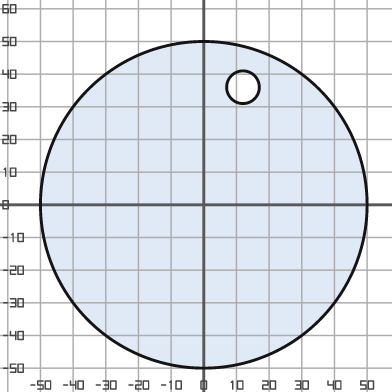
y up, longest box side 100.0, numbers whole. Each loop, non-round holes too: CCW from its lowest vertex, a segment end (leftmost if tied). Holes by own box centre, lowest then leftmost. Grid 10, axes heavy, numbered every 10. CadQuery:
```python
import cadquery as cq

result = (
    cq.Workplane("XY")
    .moveTo(0.0, 0.0)
    .circle(50.0)
    .moveTo(12.0, 36.0)
    .circle(5.0)
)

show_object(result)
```